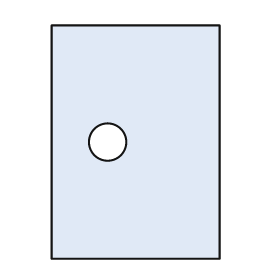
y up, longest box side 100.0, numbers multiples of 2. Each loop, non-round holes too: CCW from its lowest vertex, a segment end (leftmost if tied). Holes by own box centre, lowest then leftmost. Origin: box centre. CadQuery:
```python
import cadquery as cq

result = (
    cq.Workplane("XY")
    .moveTo(-36.0, -50.0)
    .lineTo(36.0, -50.0)
    .lineTo(36.0, 50.0)
    .lineTo(-36.0, 50.0)
    .close()
    .moveTo(-12.0, 0.0)
    .circle(8.0)
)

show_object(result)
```